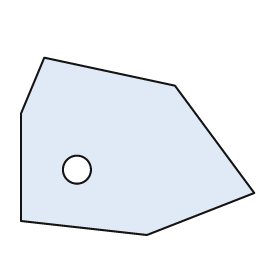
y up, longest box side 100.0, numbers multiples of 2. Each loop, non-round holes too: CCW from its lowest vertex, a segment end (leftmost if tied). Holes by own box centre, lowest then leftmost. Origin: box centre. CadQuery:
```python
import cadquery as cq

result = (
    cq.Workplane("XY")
    .moveTo(4.0, -38.0)
    .lineTo(50.0, -20.0)
    .lineTo(16.0, 26.0)
    .lineTo(-40.0, 38.0)
    .lineTo(-50.0, 14.0)
    .lineTo(-50.0, -32.0)
    .close()
    .moveTo(-26.0, -10.0)
    .circle(6.0)
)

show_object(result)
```